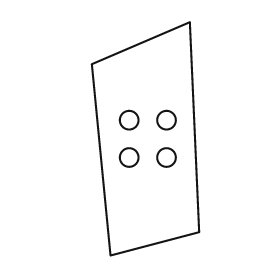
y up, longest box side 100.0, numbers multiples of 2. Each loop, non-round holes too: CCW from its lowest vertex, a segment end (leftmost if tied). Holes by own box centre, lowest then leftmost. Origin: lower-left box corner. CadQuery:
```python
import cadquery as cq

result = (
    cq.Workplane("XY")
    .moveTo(8.0, 0.0)
    .lineTo(46.0, 10.0)
    .lineTo(42.0, 100.0)
    .lineTo(0.0, 82.0)
    .close()
    .moveTo(16.0, 42.0)
    .circle(4.0)
    .moveTo(32.0, 42.0)
    .circle(4.0)
    .moveTo(16.0, 58.0)
    .circle(4.0)
    .moveTo(32.0, 58.0)
    .circle(4.0)
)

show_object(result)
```